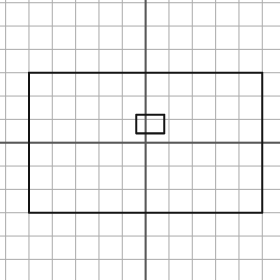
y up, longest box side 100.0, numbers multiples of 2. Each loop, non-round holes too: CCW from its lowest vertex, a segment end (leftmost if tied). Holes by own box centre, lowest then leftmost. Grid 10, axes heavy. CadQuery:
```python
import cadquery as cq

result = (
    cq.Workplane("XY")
    .moveTo(-50.0, -30.0)
    .lineTo(50.0, -30.0)
    .lineTo(50.0, 30.0)
    .lineTo(-50.0, 30.0)
    .close()
    .moveTo(-4.0, 4.0)
    .lineTo(8.0, 4.0)
    .lineTo(8.0, 12.0)
    .lineTo(-4.0, 12.0)
    .close()
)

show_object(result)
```